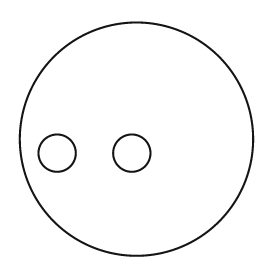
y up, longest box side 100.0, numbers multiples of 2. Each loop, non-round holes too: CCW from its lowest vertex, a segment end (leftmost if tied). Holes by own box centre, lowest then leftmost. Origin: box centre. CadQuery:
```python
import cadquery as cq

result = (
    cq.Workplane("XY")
    .moveTo(0.0, 0.0)
    .circle(50.0)
    .moveTo(-34.0, -6.0)
    .circle(8.0)
    .moveTo(-2.0, -6.0)
    .circle(8.0)
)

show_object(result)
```